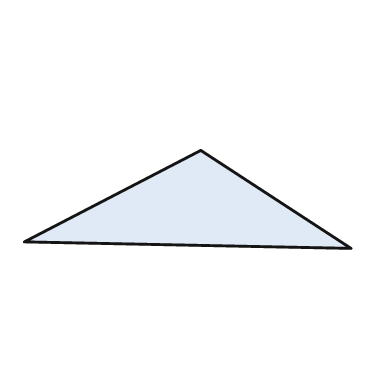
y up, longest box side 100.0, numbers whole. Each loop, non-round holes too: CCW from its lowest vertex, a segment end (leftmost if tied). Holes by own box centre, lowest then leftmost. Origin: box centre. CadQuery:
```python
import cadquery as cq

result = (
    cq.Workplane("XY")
    .moveTo(50.0, -15.0)
    .lineTo(4.0, 15.0)
    .lineTo(-50.0, -13.0)
    .close()
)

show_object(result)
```